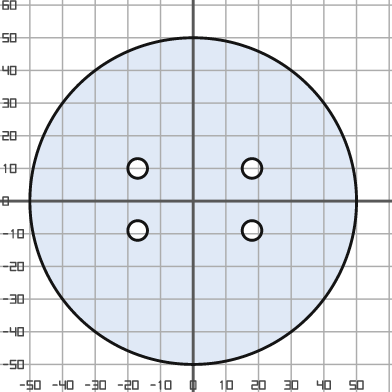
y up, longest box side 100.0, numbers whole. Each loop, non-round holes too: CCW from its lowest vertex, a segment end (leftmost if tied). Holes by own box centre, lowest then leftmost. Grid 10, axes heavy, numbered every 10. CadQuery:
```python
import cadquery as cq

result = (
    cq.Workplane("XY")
    .moveTo(0.0, 0.0)
    .circle(50.0)
    .moveTo(-17.0, -9.0)
    .circle(3.0)
    .moveTo(18.0, -9.0)
    .circle(3.0)
    .moveTo(-17.0, 10.0)
    .circle(3.0)
    .moveTo(18.0, 10.0)
    .circle(3.0)
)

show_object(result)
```